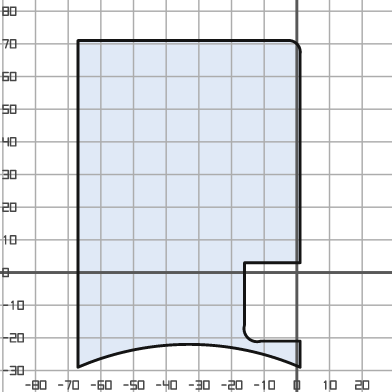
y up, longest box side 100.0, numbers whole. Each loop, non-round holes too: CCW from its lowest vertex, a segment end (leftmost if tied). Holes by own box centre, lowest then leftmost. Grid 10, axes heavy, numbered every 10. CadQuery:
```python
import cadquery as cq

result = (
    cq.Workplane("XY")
    .moveTo(-67.0, -29.0)
    .threePointArc((-33.0, -22.0), (1.0, -29.0))
    .lineTo(1.0, -21.0)
    .lineTo(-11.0, -21.0)
    .threePointArc((-15.0, -20.0), (-16.0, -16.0))
    .lineTo(-16.0, 3.0)
    .lineTo(1.0, 3.0)
    .lineTo(1.0, 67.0)
    .threePointArc((0.0, 70.0), (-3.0, 71.0))
    .lineTo(-67.0, 71.0)
    .close()
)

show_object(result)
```